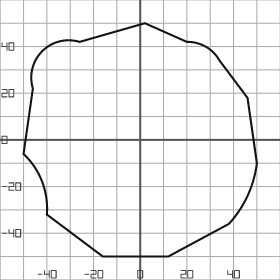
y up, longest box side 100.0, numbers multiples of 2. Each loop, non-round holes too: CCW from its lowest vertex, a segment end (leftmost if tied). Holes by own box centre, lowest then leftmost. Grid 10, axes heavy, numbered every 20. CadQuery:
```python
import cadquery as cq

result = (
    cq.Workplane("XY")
    .moveTo(-16.0, -50.0)
    .lineTo(12.0, -50.0)
    .lineTo(38.0, -36.0)
    .threePointArc((46.0, -24.0), (50.0, -10.0))
    .lineTo(46.0, 18.0)
    .lineTo(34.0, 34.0)
    .threePointArc((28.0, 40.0), (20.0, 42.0))
    .lineTo(2.0, 50.0)
    .lineTo(-26.0, 42.0)
    .threePointArc((-42.0, 38.0), (-46.0, 22.0))
    .lineTo(-50.0, -6.0)
    .threePointArc((-42.0, -18.0), (-40.0, -32.0))
    .close()
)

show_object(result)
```